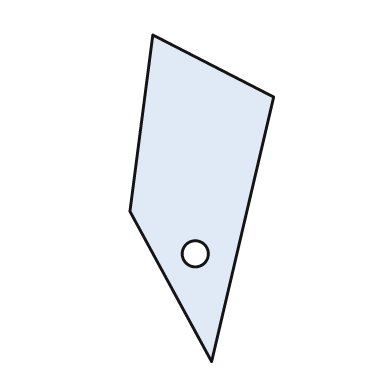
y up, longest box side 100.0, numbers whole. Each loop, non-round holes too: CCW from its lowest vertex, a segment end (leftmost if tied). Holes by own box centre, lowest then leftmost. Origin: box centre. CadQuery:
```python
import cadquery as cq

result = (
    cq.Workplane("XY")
    .moveTo(3.0, -50.0)
    .lineTo(22.0, 31.0)
    .lineTo(-15.0, 50.0)
    .lineTo(-22.0, -4.0)
    .close()
    .moveTo(-2.0, -17.0)
    .circle(4.0)
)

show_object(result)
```